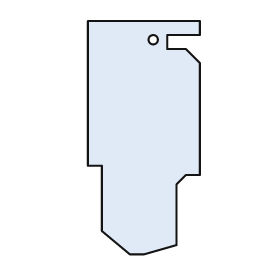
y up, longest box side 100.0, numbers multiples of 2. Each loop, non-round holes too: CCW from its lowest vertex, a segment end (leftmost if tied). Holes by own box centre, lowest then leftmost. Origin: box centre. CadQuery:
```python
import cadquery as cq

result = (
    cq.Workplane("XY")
    .moveTo(-6.0, -50.0)
    .lineTo(0.0, -50.0)
    .lineTo(14.0, -46.0)
    .lineTo(14.0, -20.0)
    .lineTo(18.0, -16.0)
    .lineTo(24.0, -16.0)
    .lineTo(24.0, 32.0)
    .lineTo(18.0, 38.0)
    .lineTo(10.0, 38.0)
    .lineTo(10.0, 44.0)
    .lineTo(24.0, 44.0)
    .lineTo(24.0, 50.0)
    .lineTo(-24.0, 50.0)
    .lineTo(-24.0, -12.0)
    .lineTo(-18.0, -12.0)
    .lineTo(-18.0, -40.0)
    .close()
    .moveTo(4.0, 42.0)
    .circle(2.0)
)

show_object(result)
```